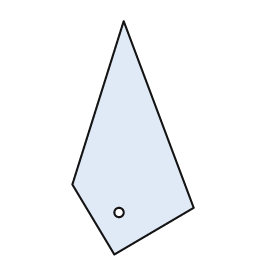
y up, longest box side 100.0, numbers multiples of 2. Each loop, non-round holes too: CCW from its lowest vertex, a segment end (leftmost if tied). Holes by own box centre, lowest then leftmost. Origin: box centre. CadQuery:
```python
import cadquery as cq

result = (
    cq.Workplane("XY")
    .moveTo(-8.0, -50.0)
    .lineTo(26.0, -30.0)
    .lineTo(-4.0, 50.0)
    .lineTo(-26.0, -20.0)
    .close()
    .moveTo(-6.0, -32.0)
    .circle(2.0)
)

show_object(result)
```